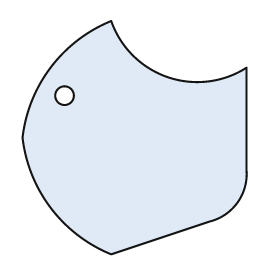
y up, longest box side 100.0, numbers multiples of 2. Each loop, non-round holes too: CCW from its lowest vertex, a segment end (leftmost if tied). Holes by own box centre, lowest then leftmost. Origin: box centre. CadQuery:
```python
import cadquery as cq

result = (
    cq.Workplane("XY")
    .moveTo(-10.0, -50.0)
    .lineTo(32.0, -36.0)
    .threePointArc((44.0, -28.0), (48.0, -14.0))
    .lineTo(48.0, 30.0)
    .threePointArc((14.0, 26.0), (-10.0, 50.0))
    .threePointArc((-36.0, 30.0), (-48.0, 0.0))
    .threePointArc((-36.0, -30.0), (-10.0, -50.0))
    .close()
    .moveTo(-30.0, 18.0)
    .circle(4.0)
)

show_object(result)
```